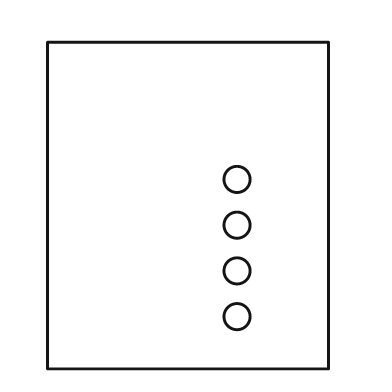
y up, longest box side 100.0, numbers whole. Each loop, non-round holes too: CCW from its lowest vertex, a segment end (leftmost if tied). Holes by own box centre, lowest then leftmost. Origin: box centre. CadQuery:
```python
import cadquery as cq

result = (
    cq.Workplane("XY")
    .moveTo(-43.0, -50.0)
    .lineTo(43.0, -50.0)
    .lineTo(43.0, 50.0)
    .lineTo(-43.0, 50.0)
    .close()
    .moveTo(15.0, -34.0)
    .circle(4.0)
    .moveTo(15.0, -20.0)
    .circle(4.0)
    .moveTo(15.0, -6.0)
    .circle(4.0)
    .moveTo(15.0, 8.0)
    .circle(4.0)
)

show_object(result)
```